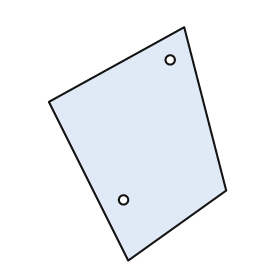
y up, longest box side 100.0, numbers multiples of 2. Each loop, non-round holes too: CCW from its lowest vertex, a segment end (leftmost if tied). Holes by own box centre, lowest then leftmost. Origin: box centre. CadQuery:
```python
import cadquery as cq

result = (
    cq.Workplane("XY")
    .moveTo(-4.0, -50.0)
    .lineTo(38.0, -20.0)
    .lineTo(20.0, 50.0)
    .lineTo(-38.0, 18.0)
    .close()
    .moveTo(-6.0, -24.0)
    .circle(2.0)
    .moveTo(14.0, 36.0)
    .circle(2.0)
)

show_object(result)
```